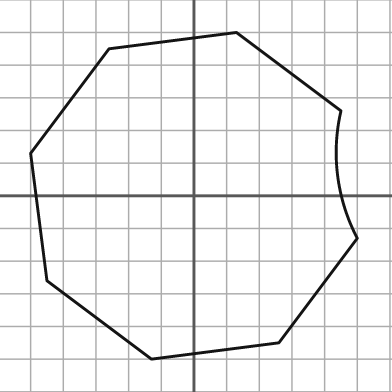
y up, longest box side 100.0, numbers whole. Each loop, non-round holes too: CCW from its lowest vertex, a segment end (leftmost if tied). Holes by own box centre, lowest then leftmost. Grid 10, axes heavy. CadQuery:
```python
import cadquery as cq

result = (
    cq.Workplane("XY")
    .moveTo(-13.0, -50.0)
    .lineTo(26.0, -45.0)
    .lineTo(50.0, -13.0)
    .threePointArc((44.0, 6.0), (45.0, 26.0))
    .lineTo(13.0, 50.0)
    .lineTo(-26.0, 45.0)
    .lineTo(-50.0, 13.0)
    .lineTo(-45.0, -26.0)
    .close()
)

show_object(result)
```